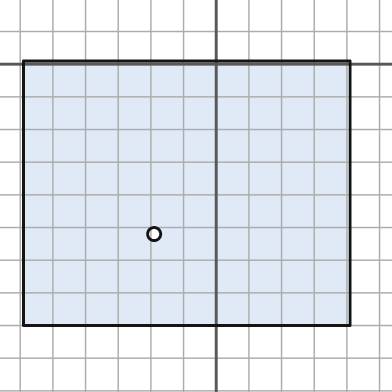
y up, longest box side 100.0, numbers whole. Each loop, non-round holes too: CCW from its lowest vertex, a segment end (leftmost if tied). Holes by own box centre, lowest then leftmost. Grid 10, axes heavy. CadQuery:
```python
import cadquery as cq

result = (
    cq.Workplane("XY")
    .moveTo(-59.0, -80.0)
    .lineTo(41.0, -80.0)
    .lineTo(41.0, 1.0)
    .lineTo(-59.0, 1.0)
    .close()
    .moveTo(-19.0, -52.0)
    .circle(2.0)
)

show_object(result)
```